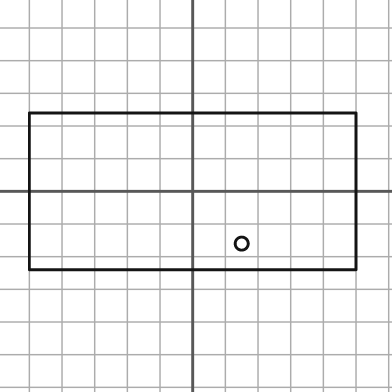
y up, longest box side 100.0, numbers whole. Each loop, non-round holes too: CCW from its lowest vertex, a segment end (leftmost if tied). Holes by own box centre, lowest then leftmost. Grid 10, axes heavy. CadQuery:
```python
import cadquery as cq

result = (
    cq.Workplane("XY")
    .moveTo(-50.0, -24.0)
    .lineTo(50.0, -24.0)
    .lineTo(50.0, 24.0)
    .lineTo(-50.0, 24.0)
    .close()
    .moveTo(15.0, -16.0)
    .circle(2.0)
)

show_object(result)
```